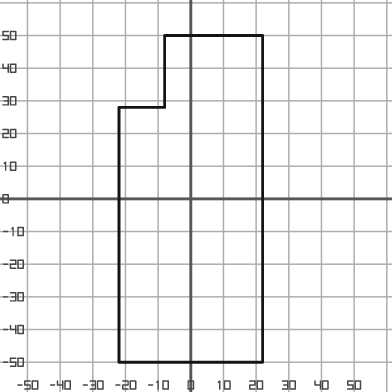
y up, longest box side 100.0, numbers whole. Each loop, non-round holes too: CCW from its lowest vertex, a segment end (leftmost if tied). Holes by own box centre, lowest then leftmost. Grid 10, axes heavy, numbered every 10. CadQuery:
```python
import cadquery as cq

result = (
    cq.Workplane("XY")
    .moveTo(-22.0, -50.0)
    .lineTo(22.0, -50.0)
    .lineTo(22.0, 50.0)
    .lineTo(-8.0, 50.0)
    .lineTo(-8.0, 28.0)
    .lineTo(-22.0, 28.0)
    .close()
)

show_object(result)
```